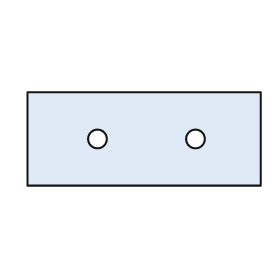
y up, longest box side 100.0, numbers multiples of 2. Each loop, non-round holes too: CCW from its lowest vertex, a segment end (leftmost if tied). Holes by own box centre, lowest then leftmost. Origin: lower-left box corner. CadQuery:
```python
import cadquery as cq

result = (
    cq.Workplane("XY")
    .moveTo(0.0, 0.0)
    .lineTo(100.0, 0.0)
    .lineTo(100.0, 40.0)
    .lineTo(0.0, 40.0)
    .close()
    .moveTo(30.0, 20.0)
    .circle(4.0)
    .moveTo(72.0, 20.0)
    .circle(4.0)
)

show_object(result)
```